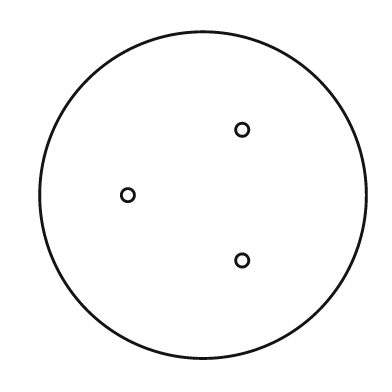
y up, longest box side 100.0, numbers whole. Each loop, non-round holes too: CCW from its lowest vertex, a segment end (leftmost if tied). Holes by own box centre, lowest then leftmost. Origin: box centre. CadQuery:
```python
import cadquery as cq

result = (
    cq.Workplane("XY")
    .moveTo(0.0, 0.0)
    .circle(50.0)
    .moveTo(12.0, -20.0)
    .circle(2.0)
    .moveTo(-23.0, 0.0)
    .circle(2.0)
    .moveTo(12.0, 20.0)
    .circle(2.0)
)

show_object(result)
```